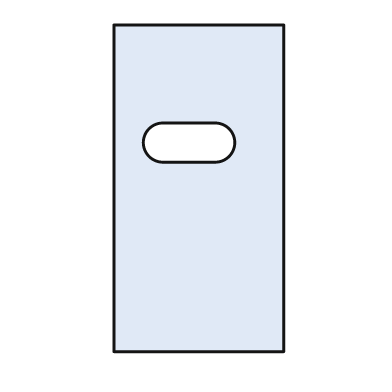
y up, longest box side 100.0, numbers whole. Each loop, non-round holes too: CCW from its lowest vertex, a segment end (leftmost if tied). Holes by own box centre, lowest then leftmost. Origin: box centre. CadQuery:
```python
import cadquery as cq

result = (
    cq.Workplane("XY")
    .moveTo(-26.0, -50.0)
    .lineTo(26.0, -50.0)
    .lineTo(26.0, 50.0)
    .lineTo(-26.0, 50.0)
    .close()
    .moveTo(-11.0, 8.0)
    .lineTo(5.0, 8.0)
    .threePointArc((11.0, 14.0), (5.0, 20.0))
    .lineTo(-11.0, 20.0)
    .threePointArc((-17.0, 14.0), (-11.0, 8.0))
    .close()
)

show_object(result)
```